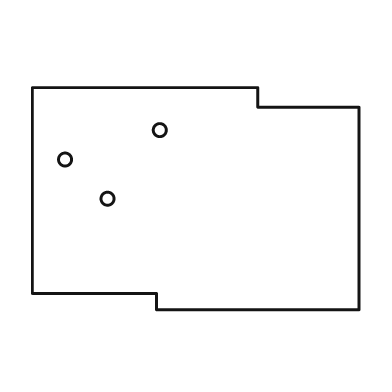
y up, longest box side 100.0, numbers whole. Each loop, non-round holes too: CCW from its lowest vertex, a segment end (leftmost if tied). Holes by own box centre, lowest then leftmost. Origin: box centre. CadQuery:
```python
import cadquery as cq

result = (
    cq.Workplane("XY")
    .moveTo(-12.0, -34.0)
    .lineTo(50.0, -34.0)
    .lineTo(50.0, 28.0)
    .lineTo(19.0, 28.0)
    .lineTo(19.0, 34.0)
    .lineTo(-50.0, 34.0)
    .lineTo(-50.0, -29.0)
    .lineTo(-12.0, -29.0)
    .close()
    .moveTo(-27.0, 0.0)
    .circle(2.0)
    .moveTo(-40.0, 12.0)
    .circle(2.0)
    .moveTo(-11.0, 21.0)
    .circle(2.0)
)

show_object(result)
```